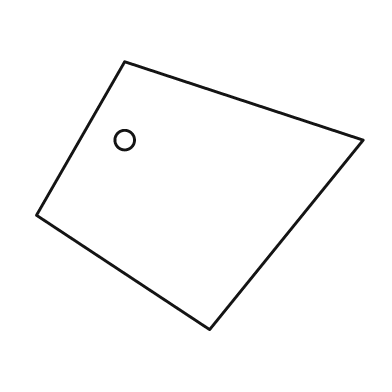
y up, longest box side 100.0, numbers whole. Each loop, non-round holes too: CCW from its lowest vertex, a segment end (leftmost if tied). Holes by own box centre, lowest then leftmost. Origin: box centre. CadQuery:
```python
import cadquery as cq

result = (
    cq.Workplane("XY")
    .moveTo(3.0, -41.0)
    .lineTo(50.0, 17.0)
    .lineTo(-23.0, 41.0)
    .lineTo(-50.0, -6.0)
    .close()
    .moveTo(-23.0, 17.0)
    .circle(3.0)
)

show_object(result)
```